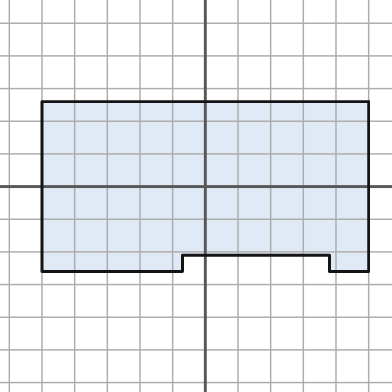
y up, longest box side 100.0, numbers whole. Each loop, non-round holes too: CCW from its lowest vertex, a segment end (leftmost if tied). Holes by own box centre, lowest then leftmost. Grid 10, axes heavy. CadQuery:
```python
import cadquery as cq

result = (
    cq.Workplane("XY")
    .moveTo(-50.0, -26.0)
    .lineTo(-7.0, -26.0)
    .lineTo(-7.0, -21.0)
    .lineTo(38.0, -21.0)
    .lineTo(38.0, -26.0)
    .lineTo(50.0, -26.0)
    .lineTo(50.0, 26.0)
    .lineTo(-50.0, 26.0)
    .close()
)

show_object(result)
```